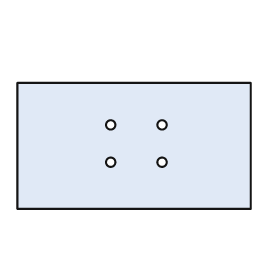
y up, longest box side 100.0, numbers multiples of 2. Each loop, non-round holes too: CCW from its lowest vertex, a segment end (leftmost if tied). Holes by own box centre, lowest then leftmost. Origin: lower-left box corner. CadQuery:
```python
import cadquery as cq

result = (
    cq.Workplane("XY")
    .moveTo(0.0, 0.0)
    .lineTo(100.0, 0.0)
    .lineTo(100.0, 54.0)
    .lineTo(0.0, 54.0)
    .close()
    .moveTo(40.0, 20.0)
    .circle(2.0)
    .moveTo(62.0, 20.0)
    .circle(2.0)
    .moveTo(40.0, 36.0)
    .circle(2.0)
    .moveTo(62.0, 36.0)
    .circle(2.0)
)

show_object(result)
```